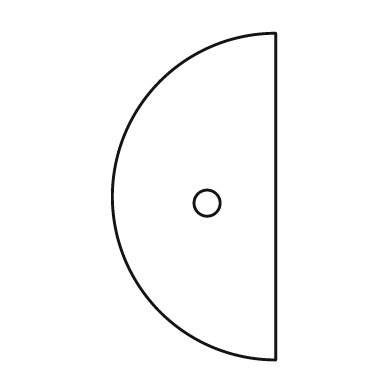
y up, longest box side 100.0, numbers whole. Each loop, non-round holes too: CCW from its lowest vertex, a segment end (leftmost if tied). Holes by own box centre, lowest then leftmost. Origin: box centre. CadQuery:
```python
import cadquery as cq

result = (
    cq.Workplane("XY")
    .moveTo(25.0, -50.0)
    .lineTo(25.0, 50.0)
    .threePointArc((-25.0, 0.0), (25.0, -50.0))
    .close()
    .moveTo(4.0, -2.0)
    .circle(4.0)
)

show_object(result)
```